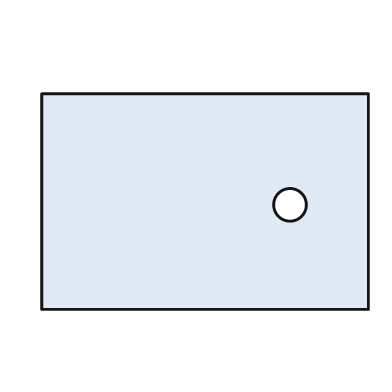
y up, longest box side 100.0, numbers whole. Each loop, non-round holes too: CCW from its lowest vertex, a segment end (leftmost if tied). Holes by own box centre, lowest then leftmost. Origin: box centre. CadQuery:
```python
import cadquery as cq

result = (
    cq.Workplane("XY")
    .moveTo(-50.0, -33.0)
    .lineTo(50.0, -33.0)
    .lineTo(50.0, 33.0)
    .lineTo(-50.0, 33.0)
    .close()
    .moveTo(26.0, -1.0)
    .circle(5.0)
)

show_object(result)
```